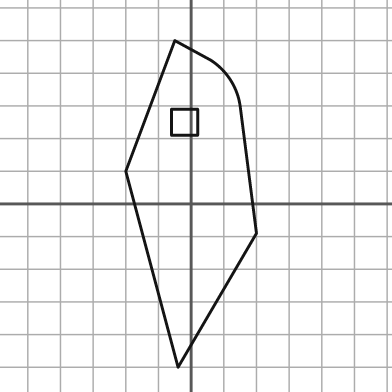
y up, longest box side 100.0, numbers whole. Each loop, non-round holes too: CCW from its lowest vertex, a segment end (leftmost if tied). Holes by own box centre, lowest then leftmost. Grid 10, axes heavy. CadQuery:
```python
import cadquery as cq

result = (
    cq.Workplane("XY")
    .moveTo(-4.0, -50.0)
    .lineTo(20.0, -9.0)
    .lineTo(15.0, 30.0)
    .threePointArc((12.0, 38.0), (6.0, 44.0))
    .lineTo(-5.0, 50.0)
    .lineTo(-20.0, 10.0)
    .close()
    .moveTo(-6.0, 21.0)
    .lineTo(2.0, 21.0)
    .lineTo(2.0, 29.0)
    .lineTo(-6.0, 29.0)
    .close()
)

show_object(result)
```